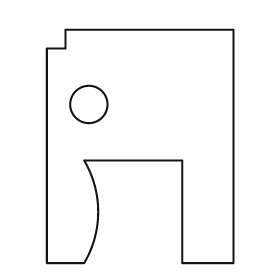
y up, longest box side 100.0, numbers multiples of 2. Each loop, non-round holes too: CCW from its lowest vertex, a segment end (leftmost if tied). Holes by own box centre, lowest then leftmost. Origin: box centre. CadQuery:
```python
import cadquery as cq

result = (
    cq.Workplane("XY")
    .moveTo(-40.0, -50.0)
    .lineTo(-24.0, -50.0)
    .threePointArc((-18.0, -28.0), (-24.0, -6.0))
    .lineTo(18.0, -6.0)
    .lineTo(18.0, -50.0)
    .lineTo(40.0, -50.0)
    .lineTo(40.0, 50.0)
    .lineTo(-32.0, 50.0)
    .lineTo(-32.0, 42.0)
    .lineTo(-40.0, 42.0)
    .close()
    .moveTo(-22.0, 18.0)
    .circle(8.0)
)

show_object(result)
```